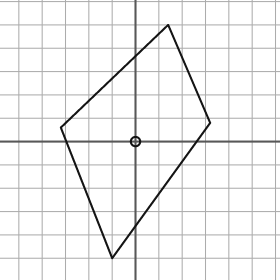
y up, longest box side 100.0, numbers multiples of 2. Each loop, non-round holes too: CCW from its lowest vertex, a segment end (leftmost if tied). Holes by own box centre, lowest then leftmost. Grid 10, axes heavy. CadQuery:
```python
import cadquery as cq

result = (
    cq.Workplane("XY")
    .moveTo(-10.0, -50.0)
    .lineTo(32.0, 8.0)
    .lineTo(14.0, 50.0)
    .lineTo(-32.0, 6.0)
    .close()
    .moveTo(0.0, 0.0)
    .circle(2.0)
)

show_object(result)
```